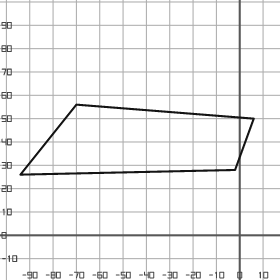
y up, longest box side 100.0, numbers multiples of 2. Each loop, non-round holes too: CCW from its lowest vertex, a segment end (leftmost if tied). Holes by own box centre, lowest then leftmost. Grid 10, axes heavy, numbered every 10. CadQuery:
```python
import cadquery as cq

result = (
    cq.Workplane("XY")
    .moveTo(-94.0, 26.0)
    .lineTo(-2.0, 28.0)
    .lineTo(6.0, 50.0)
    .lineTo(-70.0, 56.0)
    .close()
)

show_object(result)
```